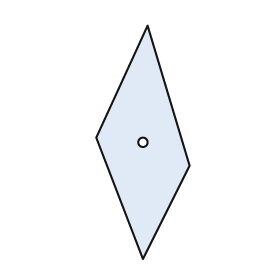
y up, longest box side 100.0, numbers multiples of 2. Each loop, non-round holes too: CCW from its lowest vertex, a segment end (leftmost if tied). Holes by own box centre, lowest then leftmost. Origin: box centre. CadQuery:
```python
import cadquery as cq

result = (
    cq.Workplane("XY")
    .moveTo(0.0, -50.0)
    .lineTo(20.0, -10.0)
    .lineTo(2.0, 50.0)
    .lineTo(-20.0, 2.0)
    .close()
    .moveTo(0.0, 0.0)
    .circle(2.0)
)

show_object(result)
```